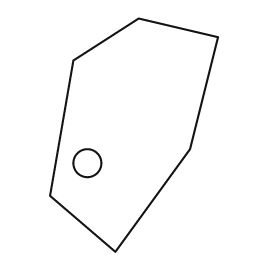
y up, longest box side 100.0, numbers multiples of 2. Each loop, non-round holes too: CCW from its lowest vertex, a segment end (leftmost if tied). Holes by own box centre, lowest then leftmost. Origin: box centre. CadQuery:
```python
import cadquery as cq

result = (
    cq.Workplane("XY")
    .moveTo(-8.0, -50.0)
    .lineTo(24.0, -6.0)
    .lineTo(36.0, 42.0)
    .lineTo(2.0, 50.0)
    .lineTo(-26.0, 32.0)
    .lineTo(-36.0, -26.0)
    .close()
    .moveTo(-20.0, -12.0)
    .circle(6.0)
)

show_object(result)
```